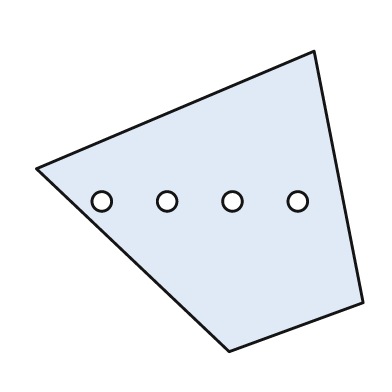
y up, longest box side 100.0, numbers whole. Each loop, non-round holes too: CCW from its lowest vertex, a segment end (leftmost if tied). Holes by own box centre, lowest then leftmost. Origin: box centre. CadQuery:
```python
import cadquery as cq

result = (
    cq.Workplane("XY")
    .moveTo(9.0, -46.0)
    .lineTo(50.0, -31.0)
    .lineTo(35.0, 46.0)
    .lineTo(-50.0, 10.0)
    .close()
    .moveTo(-30.0, 0.0)
    .circle(3.0)
    .moveTo(-10.0, 0.0)
    .circle(3.0)
    .moveTo(10.0, 0.0)
    .circle(3.0)
    .moveTo(30.0, 0.0)
    .circle(3.0)
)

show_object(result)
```